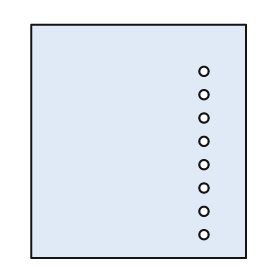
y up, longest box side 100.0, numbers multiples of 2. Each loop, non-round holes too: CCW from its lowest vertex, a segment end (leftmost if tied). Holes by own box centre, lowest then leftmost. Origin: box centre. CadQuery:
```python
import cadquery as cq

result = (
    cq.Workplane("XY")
    .moveTo(-46.0, -50.0)
    .lineTo(46.0, -50.0)
    .lineTo(46.0, 50.0)
    .lineTo(-46.0, 50.0)
    .close()
    .moveTo(28.0, -40.0)
    .circle(2.0)
    .moveTo(28.0, -30.0)
    .circle(2.0)
    .moveTo(28.0, -20.0)
    .circle(2.0)
    .moveTo(28.0, -10.0)
    .circle(2.0)
    .moveTo(28.0, 0.0)
    .circle(2.0)
    .moveTo(28.0, 10.0)
    .circle(2.0)
    .moveTo(28.0, 20.0)
    .circle(2.0)
    .moveTo(28.0, 30.0)
    .circle(2.0)
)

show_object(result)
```